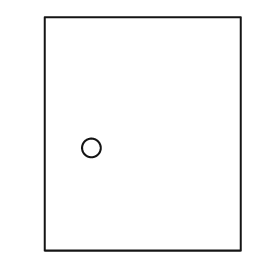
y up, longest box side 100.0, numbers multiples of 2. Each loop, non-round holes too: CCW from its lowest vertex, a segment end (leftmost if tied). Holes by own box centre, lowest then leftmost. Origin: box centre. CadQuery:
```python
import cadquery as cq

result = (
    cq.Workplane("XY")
    .moveTo(-42.0, -50.0)
    .lineTo(42.0, -50.0)
    .lineTo(42.0, 50.0)
    .lineTo(-42.0, 50.0)
    .close()
    .moveTo(-22.0, -6.0)
    .circle(4.0)
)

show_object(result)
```